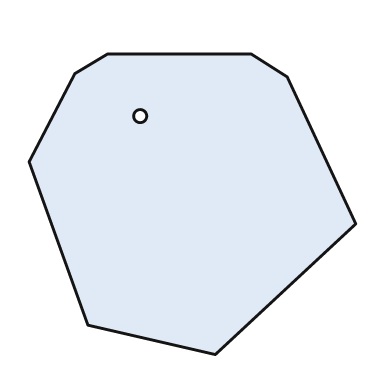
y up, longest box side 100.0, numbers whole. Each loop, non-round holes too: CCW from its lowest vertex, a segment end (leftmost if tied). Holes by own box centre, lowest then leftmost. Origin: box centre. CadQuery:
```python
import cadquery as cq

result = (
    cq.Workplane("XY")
    .moveTo(7.0, -46.0)
    .lineTo(50.0, -6.0)
    .lineTo(29.0, 39.0)
    .lineTo(18.0, 46.0)
    .lineTo(-26.0, 46.0)
    .lineTo(-36.0, 40.0)
    .lineTo(-50.0, 13.0)
    .lineTo(-32.0, -37.0)
    .close()
    .moveTo(-16.0, 27.0)
    .circle(2.0)
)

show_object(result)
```